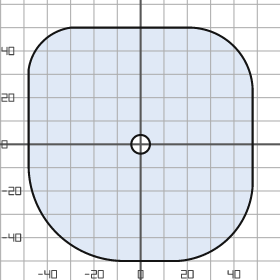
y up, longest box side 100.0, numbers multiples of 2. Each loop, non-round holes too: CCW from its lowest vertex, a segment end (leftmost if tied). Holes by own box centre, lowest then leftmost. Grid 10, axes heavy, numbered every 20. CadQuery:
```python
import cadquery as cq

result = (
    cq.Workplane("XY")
    .moveTo(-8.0, -50.0)
    .lineTo(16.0, -50.0)
    .threePointArc((38.0, -40.0), (48.0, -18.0))
    .lineTo(48.0, 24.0)
    .threePointArc((40.0, 42.0), (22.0, 50.0))
    .lineTo(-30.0, 50.0)
    .threePointArc((-42.0, 44.0), (-48.0, 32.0))
    .lineTo(-48.0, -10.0)
    .threePointArc((-36.0, -38.0), (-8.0, -50.0))
    .close()
    .moveTo(0.0, 0.0)
    .circle(4.0)
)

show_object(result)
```